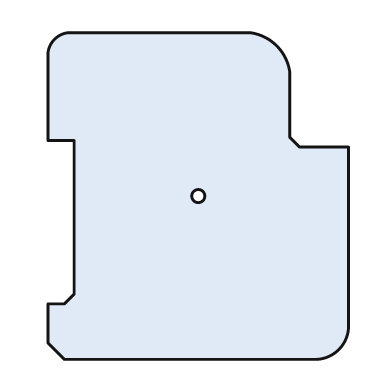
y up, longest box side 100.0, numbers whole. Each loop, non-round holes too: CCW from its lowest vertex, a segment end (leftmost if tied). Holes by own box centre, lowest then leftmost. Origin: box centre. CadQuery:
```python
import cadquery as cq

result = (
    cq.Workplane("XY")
    .moveTo(-41.0, -50.0)
    .lineTo(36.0, -50.0)
    .threePointArc((43.0, -47.0), (46.0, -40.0))
    .lineTo(46.0, 15.0)
    .lineTo(31.0, 15.0)
    .lineTo(28.0, 18.0)
    .lineTo(28.0, 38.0)
    .threePointArc((24.0, 46.0), (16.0, 50.0))
    .lineTo(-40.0, 50.0)
    .threePointArc((-44.0, 48.0), (-46.0, 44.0))
    .lineTo(-46.0, 17.0)
    .lineTo(-38.0, 17.0)
    .lineTo(-38.0, -30.0)
    .lineTo(-41.0, -33.0)
    .lineTo(-46.0, -33.0)
    .lineTo(-46.0, -45.0)
    .close()
    .moveTo(0.0, 0.0)
    .circle(2.0)
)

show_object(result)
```